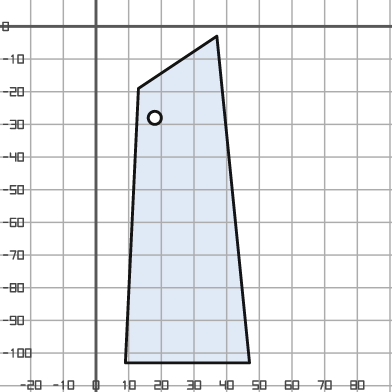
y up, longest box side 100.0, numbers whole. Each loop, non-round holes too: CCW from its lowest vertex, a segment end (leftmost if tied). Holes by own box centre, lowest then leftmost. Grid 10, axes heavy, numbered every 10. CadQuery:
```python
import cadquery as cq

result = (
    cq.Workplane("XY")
    .moveTo(9.0, -103.0)
    .lineTo(47.0, -103.0)
    .lineTo(37.0, -3.0)
    .lineTo(13.0, -19.0)
    .close()
    .moveTo(18.0, -28.0)
    .circle(2.0)
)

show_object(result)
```